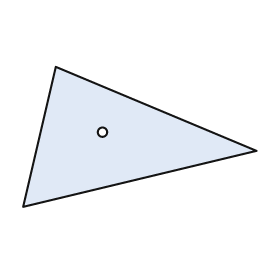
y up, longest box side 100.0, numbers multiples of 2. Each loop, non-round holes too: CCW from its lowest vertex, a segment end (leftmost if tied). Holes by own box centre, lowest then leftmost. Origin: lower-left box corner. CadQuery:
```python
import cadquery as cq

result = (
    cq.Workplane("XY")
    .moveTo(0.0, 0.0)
    .lineTo(100.0, 24.0)
    .lineTo(14.0, 60.0)
    .close()
    .moveTo(34.0, 32.0)
    .circle(2.0)
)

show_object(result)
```